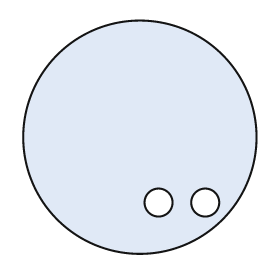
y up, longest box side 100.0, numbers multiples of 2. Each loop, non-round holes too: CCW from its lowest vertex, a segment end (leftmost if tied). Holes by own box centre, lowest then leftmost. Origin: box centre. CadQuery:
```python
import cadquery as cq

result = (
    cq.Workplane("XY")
    .moveTo(0.0, 0.0)
    .circle(50.0)
    .moveTo(8.0, -28.0)
    .circle(6.0)
    .moveTo(28.0, -28.0)
    .circle(6.0)
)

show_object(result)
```